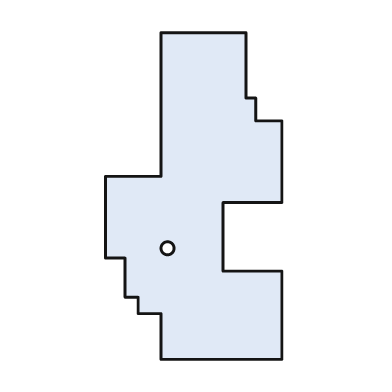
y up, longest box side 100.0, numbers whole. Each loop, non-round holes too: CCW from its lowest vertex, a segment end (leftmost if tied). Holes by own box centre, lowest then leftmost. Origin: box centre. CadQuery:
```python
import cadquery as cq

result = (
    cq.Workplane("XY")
    .moveTo(-10.0, -50.0)
    .lineTo(27.0, -50.0)
    .lineTo(27.0, -23.0)
    .lineTo(9.0, -23.0)
    .lineTo(9.0, -2.0)
    .lineTo(27.0, -2.0)
    .lineTo(27.0, 23.0)
    .lineTo(19.0, 23.0)
    .lineTo(19.0, 30.0)
    .lineTo(16.0, 30.0)
    .lineTo(16.0, 50.0)
    .lineTo(-10.0, 50.0)
    .lineTo(-10.0, 6.0)
    .lineTo(-27.0, 6.0)
    .lineTo(-27.0, -19.0)
    .lineTo(-21.0, -19.0)
    .lineTo(-21.0, -31.0)
    .lineTo(-17.0, -31.0)
    .lineTo(-17.0, -36.0)
    .lineTo(-10.0, -36.0)
    .close()
    .moveTo(-8.0, -16.0)
    .circle(2.0)
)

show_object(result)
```